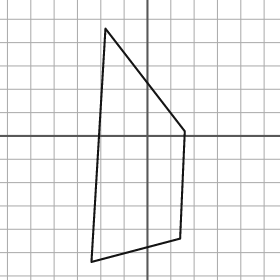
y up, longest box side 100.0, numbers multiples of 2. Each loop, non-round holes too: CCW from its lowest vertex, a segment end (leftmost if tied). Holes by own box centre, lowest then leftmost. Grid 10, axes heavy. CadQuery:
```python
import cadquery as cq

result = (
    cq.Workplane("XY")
    .moveTo(-24.0, -54.0)
    .lineTo(14.0, -44.0)
    .lineTo(16.0, 2.0)
    .lineTo(-18.0, 46.0)
    .close()
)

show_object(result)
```